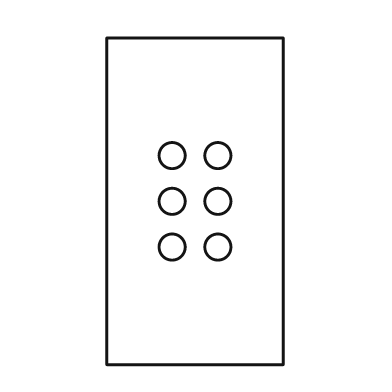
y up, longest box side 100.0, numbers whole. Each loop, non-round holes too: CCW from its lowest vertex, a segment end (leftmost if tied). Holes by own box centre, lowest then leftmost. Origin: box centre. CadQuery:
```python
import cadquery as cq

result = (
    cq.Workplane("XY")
    .moveTo(-27.0, -50.0)
    .lineTo(27.0, -50.0)
    .lineTo(27.0, 50.0)
    .lineTo(-27.0, 50.0)
    .close()
    .moveTo(-7.0, -14.0)
    .circle(4.0)
    .moveTo(7.0, -14.0)
    .circle(4.0)
    .moveTo(-7.0, 0.0)
    .circle(4.0)
    .moveTo(7.0, 0.0)
    .circle(4.0)
    .moveTo(-7.0, 14.0)
    .circle(4.0)
    .moveTo(7.0, 14.0)
    .circle(4.0)
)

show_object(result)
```